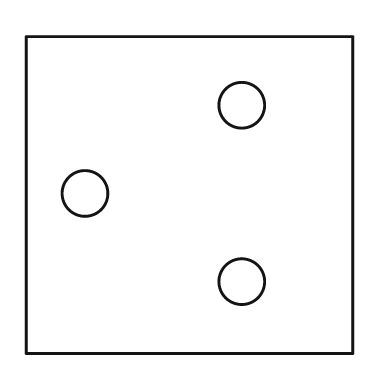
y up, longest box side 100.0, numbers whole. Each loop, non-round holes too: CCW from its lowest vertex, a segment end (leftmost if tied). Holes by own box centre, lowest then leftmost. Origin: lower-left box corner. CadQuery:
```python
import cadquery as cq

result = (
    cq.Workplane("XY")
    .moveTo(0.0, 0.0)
    .lineTo(100.0, 0.0)
    .lineTo(100.0, 97.0)
    .lineTo(0.0, 97.0)
    .close()
    .moveTo(66.0, 22.0)
    .circle(7.0)
    .moveTo(18.0, 49.0)
    .circle(7.0)
    .moveTo(66.0, 76.0)
    .circle(7.0)
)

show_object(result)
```